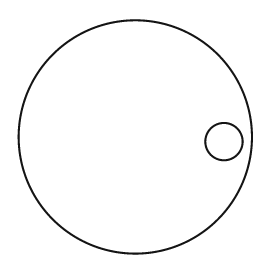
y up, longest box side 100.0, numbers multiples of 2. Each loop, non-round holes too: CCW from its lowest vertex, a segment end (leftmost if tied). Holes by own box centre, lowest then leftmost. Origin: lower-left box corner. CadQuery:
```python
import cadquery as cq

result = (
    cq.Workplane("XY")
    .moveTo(50.0, 50.0)
    .circle(50.0)
    .moveTo(88.0, 48.0)
    .circle(8.0)
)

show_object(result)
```